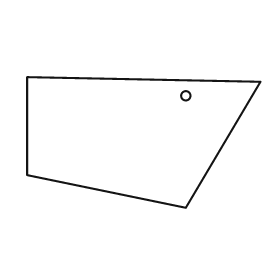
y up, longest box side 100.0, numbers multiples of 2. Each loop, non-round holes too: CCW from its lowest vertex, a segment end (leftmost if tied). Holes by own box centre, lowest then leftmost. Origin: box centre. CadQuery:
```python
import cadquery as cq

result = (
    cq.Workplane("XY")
    .moveTo(18.0, -28.0)
    .lineTo(50.0, 26.0)
    .lineTo(-50.0, 28.0)
    .lineTo(-50.0, -14.0)
    .close()
    .moveTo(18.0, 20.0)
    .circle(2.0)
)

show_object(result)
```